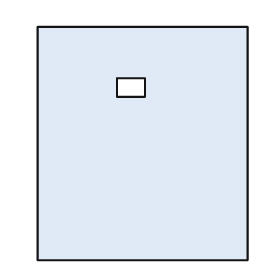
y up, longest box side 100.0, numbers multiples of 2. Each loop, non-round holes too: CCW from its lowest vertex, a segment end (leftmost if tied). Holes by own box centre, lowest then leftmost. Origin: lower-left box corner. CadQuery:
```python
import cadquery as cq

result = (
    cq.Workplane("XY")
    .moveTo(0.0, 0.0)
    .lineTo(90.0, 0.0)
    .lineTo(90.0, 100.0)
    .lineTo(0.0, 100.0)
    .close()
    .moveTo(34.0, 70.0)
    .lineTo(46.0, 70.0)
    .lineTo(46.0, 78.0)
    .lineTo(34.0, 78.0)
    .close()
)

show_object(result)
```